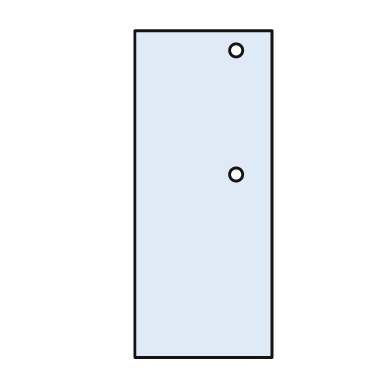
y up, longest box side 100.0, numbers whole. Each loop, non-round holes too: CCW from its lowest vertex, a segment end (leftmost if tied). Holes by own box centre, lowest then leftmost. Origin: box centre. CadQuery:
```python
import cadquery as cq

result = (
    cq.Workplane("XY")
    .moveTo(-21.0, -50.0)
    .lineTo(21.0, -50.0)
    .lineTo(21.0, 50.0)
    .lineTo(-21.0, 50.0)
    .close()
    .moveTo(10.0, 6.0)
    .circle(2.0)
    .moveTo(10.0, 44.0)
    .circle(2.0)
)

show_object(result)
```